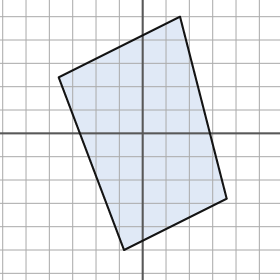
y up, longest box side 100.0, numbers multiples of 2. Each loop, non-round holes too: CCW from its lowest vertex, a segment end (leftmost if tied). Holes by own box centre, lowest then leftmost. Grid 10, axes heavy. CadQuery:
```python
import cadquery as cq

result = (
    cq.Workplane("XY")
    .moveTo(-8.0, -50.0)
    .lineTo(36.0, -28.0)
    .lineTo(16.0, 50.0)
    .lineTo(-36.0, 24.0)
    .close()
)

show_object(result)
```